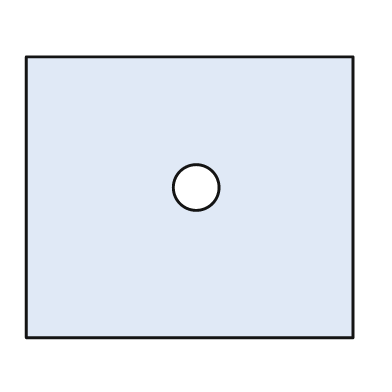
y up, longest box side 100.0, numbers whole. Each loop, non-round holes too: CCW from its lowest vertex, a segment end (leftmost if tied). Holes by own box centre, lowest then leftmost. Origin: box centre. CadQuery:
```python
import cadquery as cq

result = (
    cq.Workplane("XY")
    .moveTo(-50.0, -43.0)
    .lineTo(50.0, -43.0)
    .lineTo(50.0, 43.0)
    .lineTo(-50.0, 43.0)
    .close()
    .moveTo(2.0, 3.0)
    .circle(7.0)
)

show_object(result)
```